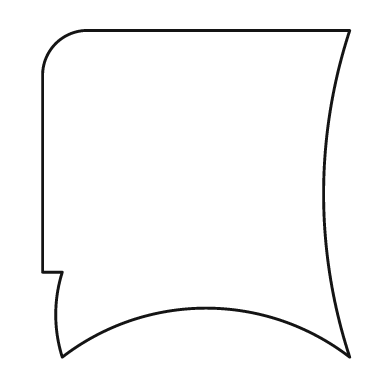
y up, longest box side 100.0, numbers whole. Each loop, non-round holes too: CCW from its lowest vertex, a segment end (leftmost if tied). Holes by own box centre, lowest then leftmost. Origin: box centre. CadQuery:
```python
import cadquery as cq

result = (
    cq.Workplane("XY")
    .moveTo(-41.0, -50.0)
    .threePointArc((3.0, -35.0), (47.0, -50.0))
    .threePointArc((39.0, 0.0), (47.0, 50.0))
    .lineTo(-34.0, 50.0)
    .threePointArc((-43.0, 46.0), (-47.0, 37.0))
    .lineTo(-47.0, -24.0)
    .lineTo(-41.0, -24.0)
    .threePointArc((-43.0, -37.0), (-41.0, -50.0))
    .close()
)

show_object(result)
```